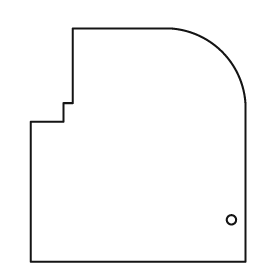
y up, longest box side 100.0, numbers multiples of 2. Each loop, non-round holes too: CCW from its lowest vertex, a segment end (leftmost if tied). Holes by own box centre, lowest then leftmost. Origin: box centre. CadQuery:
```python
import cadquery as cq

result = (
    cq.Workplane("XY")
    .moveTo(-46.0, -50.0)
    .lineTo(46.0, -50.0)
    .lineTo(46.0, 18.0)
    .threePointArc((36.0, 40.0), (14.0, 50.0))
    .lineTo(-28.0, 50.0)
    .lineTo(-28.0, 18.0)
    .lineTo(-32.0, 18.0)
    .lineTo(-32.0, 10.0)
    .lineTo(-46.0, 10.0)
    .close()
    .moveTo(40.0, -32.0)
    .circle(2.0)
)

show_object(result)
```